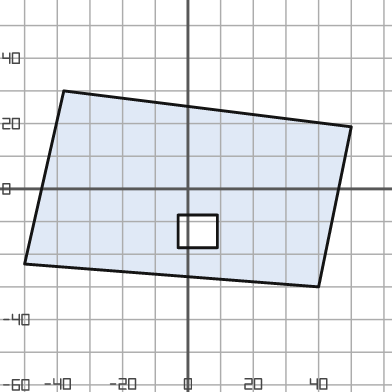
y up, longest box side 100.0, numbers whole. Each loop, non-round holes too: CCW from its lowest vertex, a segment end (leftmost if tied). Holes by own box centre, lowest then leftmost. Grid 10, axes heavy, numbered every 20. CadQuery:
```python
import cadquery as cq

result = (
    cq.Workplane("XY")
    .moveTo(40.0, -30.0)
    .lineTo(50.0, 19.0)
    .lineTo(-38.0, 30.0)
    .lineTo(-50.0, -23.0)
    .close()
    .moveTo(-3.0, -18.0)
    .lineTo(9.0, -18.0)
    .lineTo(9.0, -8.0)
    .lineTo(-3.0, -8.0)
    .close()
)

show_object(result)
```